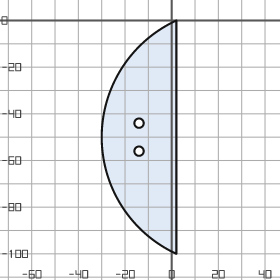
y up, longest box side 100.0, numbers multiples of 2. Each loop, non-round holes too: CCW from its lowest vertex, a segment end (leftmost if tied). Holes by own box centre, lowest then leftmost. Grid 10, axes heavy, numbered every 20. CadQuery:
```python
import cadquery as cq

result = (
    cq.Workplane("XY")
    .moveTo(2.0, -100.0)
    .lineTo(2.0, 0.0)
    .threePointArc((-30.0, -50.0), (2.0, -100.0))
    .close()
    .moveTo(-14.0, -56.0)
    .circle(2.0)
    .moveTo(-14.0, -44.0)
    .circle(2.0)
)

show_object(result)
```